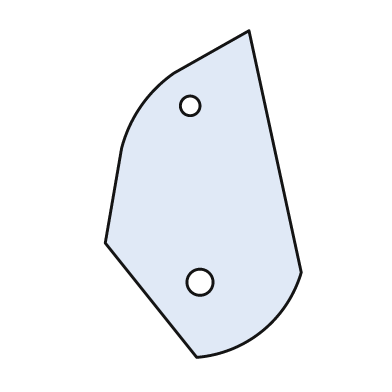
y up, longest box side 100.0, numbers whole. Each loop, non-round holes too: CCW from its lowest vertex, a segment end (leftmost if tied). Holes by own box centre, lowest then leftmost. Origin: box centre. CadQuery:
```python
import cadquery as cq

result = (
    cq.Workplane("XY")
    .moveTo(-2.0, -50.0)
    .threePointArc((18.0, -42.0), (30.0, -24.0))
    .lineTo(14.0, 50.0)
    .lineTo(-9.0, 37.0)
    .threePointArc((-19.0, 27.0), (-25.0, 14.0))
    .lineTo(-30.0, -15.0)
    .close()
    .moveTo(-1.0, -27.0)
    .circle(4.0)
    .moveTo(-4.0, 27.0)
    .circle(3.0)
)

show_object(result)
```